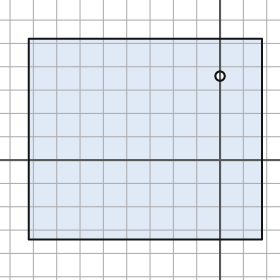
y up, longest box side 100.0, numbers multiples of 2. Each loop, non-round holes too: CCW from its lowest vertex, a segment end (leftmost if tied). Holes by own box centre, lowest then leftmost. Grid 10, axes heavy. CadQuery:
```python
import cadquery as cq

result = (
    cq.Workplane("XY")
    .moveTo(-82.0, -34.0)
    .lineTo(18.0, -34.0)
    .lineTo(18.0, 52.0)
    .lineTo(-82.0, 52.0)
    .close()
    .moveTo(0.0, 36.0)
    .circle(2.0)
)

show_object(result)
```